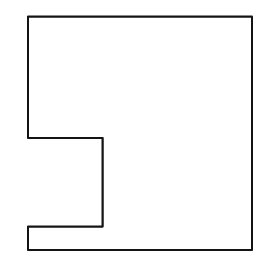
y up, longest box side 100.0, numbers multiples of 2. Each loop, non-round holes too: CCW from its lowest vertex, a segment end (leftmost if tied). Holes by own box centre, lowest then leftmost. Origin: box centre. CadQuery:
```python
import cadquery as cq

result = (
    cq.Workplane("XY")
    .moveTo(-48.0, -50.0)
    .lineTo(48.0, -50.0)
    .lineTo(48.0, 50.0)
    .lineTo(-48.0, 50.0)
    .lineTo(-48.0, -2.0)
    .lineTo(-16.0, -2.0)
    .lineTo(-16.0, -40.0)
    .lineTo(-48.0, -40.0)
    .close()
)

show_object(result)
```